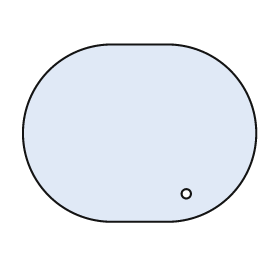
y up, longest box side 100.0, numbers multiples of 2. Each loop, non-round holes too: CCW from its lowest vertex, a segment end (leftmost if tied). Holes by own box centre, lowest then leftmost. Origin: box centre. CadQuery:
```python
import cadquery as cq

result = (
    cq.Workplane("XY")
    .moveTo(-12.0, -38.0)
    .lineTo(12.0, -38.0)
    .threePointArc((50.0, 0.0), (12.0, 38.0))
    .lineTo(-12.0, 38.0)
    .threePointArc((-50.0, 0.0), (-12.0, -38.0))
    .close()
    .moveTo(20.0, -26.0)
    .circle(2.0)
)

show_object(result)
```